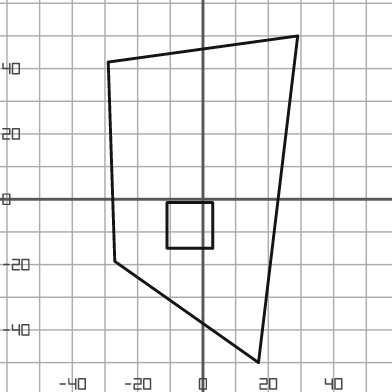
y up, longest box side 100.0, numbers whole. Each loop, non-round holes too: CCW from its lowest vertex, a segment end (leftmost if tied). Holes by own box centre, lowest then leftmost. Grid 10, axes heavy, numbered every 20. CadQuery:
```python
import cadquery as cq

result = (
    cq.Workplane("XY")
    .moveTo(17.0, -50.0)
    .lineTo(29.0, 50.0)
    .lineTo(-29.0, 42.0)
    .lineTo(-27.0, -19.0)
    .close()
    .moveTo(-11.0, -15.0)
    .lineTo(3.0, -15.0)
    .lineTo(3.0, -1.0)
    .lineTo(-11.0, -1.0)
    .close()
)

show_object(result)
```